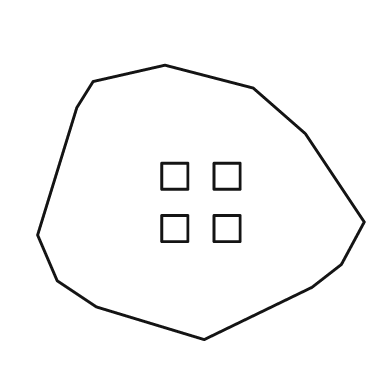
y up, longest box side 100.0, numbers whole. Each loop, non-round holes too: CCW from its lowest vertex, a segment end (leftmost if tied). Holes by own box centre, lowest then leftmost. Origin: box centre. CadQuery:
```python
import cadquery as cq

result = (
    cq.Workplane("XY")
    .moveTo(1.0, -42.0)
    .lineTo(34.0, -26.0)
    .lineTo(43.0, -19.0)
    .lineTo(50.0, -6.0)
    .lineTo(32.0, 21.0)
    .lineTo(16.0, 35.0)
    .lineTo(-11.0, 42.0)
    .lineTo(-33.0, 37.0)
    .lineTo(-38.0, 29.0)
    .lineTo(-50.0, -10.0)
    .lineTo(-44.0, -24.0)
    .lineTo(-32.0, -32.0)
    .close()
    .moveTo(-12.0, -12.0)
    .lineTo(-4.0, -12.0)
    .lineTo(-4.0, -4.0)
    .lineTo(-12.0, -4.0)
    .close()
    .moveTo(4.0, -12.0)
    .lineTo(12.0, -12.0)
    .lineTo(12.0, -4.0)
    .lineTo(4.0, -4.0)
    .close()
    .moveTo(-12.0, 4.0)
    .lineTo(-4.0, 4.0)
    .lineTo(-4.0, 12.0)
    .lineTo(-12.0, 12.0)
    .close()
    .moveTo(4.0, 4.0)
    .lineTo(12.0, 4.0)
    .lineTo(12.0, 12.0)
    .lineTo(4.0, 12.0)
    .close()
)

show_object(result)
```